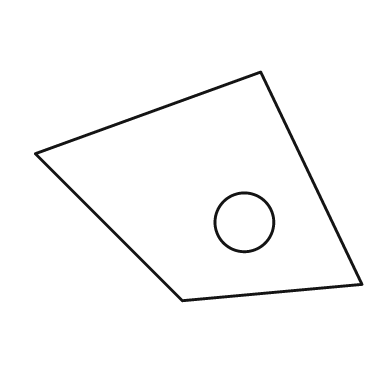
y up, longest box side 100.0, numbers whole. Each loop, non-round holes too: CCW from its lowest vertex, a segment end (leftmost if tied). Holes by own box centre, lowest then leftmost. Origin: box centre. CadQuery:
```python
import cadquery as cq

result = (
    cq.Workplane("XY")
    .moveTo(-5.0, -35.0)
    .lineTo(50.0, -30.0)
    .lineTo(19.0, 35.0)
    .lineTo(-50.0, 10.0)
    .close()
    .moveTo(14.0, -11.0)
    .circle(9.0)
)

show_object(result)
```